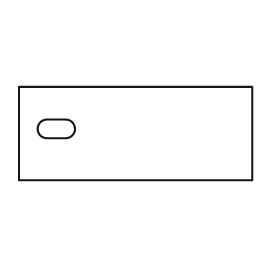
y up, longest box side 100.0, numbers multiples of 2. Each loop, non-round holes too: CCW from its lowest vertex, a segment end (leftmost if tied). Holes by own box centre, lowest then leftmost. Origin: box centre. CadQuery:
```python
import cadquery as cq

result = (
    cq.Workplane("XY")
    .moveTo(-50.0, -20.0)
    .lineTo(50.0, -20.0)
    .lineTo(50.0, 20.0)
    .lineTo(-50.0, 20.0)
    .close()
    .moveTo(-38.0, -2.0)
    .lineTo(-30.0, -2.0)
    .threePointArc((-26.0, 2.0), (-30.0, 6.0))
    .lineTo(-38.0, 6.0)
    .threePointArc((-42.0, 2.0), (-38.0, -2.0))
    .close()
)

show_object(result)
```